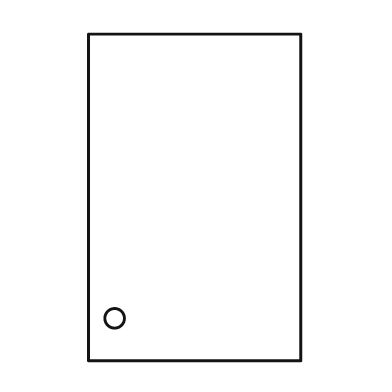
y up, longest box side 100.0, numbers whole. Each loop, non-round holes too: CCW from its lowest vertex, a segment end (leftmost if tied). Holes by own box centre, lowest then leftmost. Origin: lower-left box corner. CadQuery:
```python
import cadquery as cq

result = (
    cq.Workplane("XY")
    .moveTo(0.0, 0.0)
    .lineTo(65.0, 0.0)
    .lineTo(65.0, 100.0)
    .lineTo(0.0, 100.0)
    .close()
    .moveTo(8.0, 13.0)
    .circle(3.0)
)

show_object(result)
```